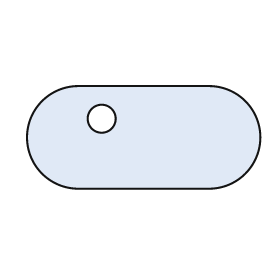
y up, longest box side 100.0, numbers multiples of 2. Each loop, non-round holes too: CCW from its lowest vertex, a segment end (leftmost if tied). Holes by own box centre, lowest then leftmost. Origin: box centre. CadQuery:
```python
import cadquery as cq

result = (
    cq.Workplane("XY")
    .moveTo(-28.0, -22.0)
    .lineTo(28.0, -22.0)
    .threePointArc((50.0, 0.0), (28.0, 22.0))
    .lineTo(-28.0, 22.0)
    .threePointArc((-50.0, 0.0), (-28.0, -22.0))
    .close()
    .moveTo(-18.0, 8.0)
    .circle(6.0)
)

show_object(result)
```